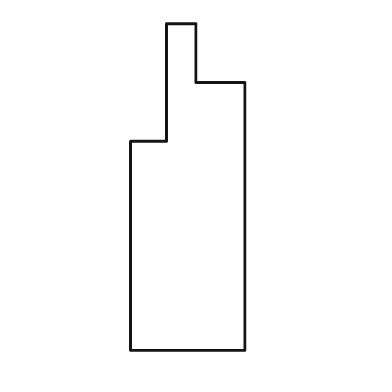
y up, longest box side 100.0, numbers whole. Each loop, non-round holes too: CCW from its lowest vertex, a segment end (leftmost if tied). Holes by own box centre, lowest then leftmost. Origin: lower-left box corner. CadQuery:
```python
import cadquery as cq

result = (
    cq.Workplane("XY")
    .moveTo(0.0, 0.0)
    .lineTo(35.0, 0.0)
    .lineTo(35.0, 82.0)
    .lineTo(20.0, 82.0)
    .lineTo(20.0, 100.0)
    .lineTo(11.0, 100.0)
    .lineTo(11.0, 64.0)
    .lineTo(0.0, 64.0)
    .close()
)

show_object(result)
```